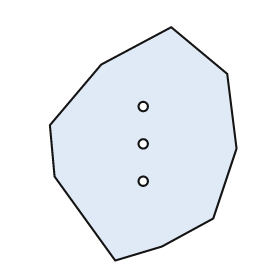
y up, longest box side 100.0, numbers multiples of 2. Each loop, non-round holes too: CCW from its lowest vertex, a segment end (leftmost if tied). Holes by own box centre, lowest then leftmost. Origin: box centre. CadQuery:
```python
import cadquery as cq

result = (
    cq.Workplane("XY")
    .moveTo(-12.0, -50.0)
    .lineTo(8.0, -44.0)
    .lineTo(30.0, -32.0)
    .lineTo(40.0, -2.0)
    .lineTo(36.0, 30.0)
    .lineTo(12.0, 50.0)
    .lineTo(-18.0, 34.0)
    .lineTo(-40.0, 8.0)
    .lineTo(-38.0, -14.0)
    .close()
    .moveTo(0.0, -16.0)
    .circle(2.0)
    .moveTo(0.0, 0.0)
    .circle(2.0)
    .moveTo(0.0, 16.0)
    .circle(2.0)
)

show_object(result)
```